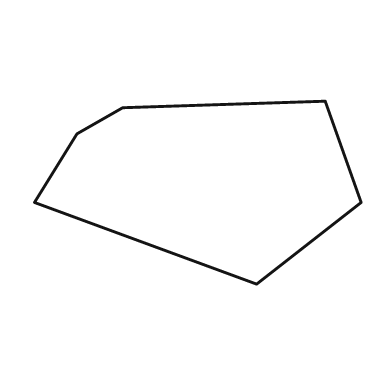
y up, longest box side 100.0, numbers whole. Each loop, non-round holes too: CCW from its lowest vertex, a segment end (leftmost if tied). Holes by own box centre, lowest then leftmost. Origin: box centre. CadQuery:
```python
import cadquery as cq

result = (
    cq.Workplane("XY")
    .moveTo(18.0, -28.0)
    .lineTo(50.0, -3.0)
    .lineTo(39.0, 28.0)
    .lineTo(-23.0, 26.0)
    .lineTo(-37.0, 18.0)
    .lineTo(-50.0, -3.0)
    .close()
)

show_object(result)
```